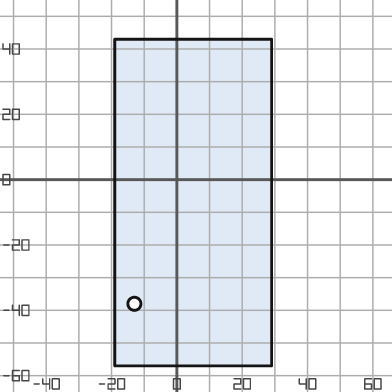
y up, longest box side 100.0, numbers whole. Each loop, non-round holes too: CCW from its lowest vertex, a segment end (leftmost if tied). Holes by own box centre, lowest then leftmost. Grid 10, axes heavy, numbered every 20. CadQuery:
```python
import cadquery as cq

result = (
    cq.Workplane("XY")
    .moveTo(-19.0, -57.0)
    .lineTo(29.0, -57.0)
    .lineTo(29.0, 43.0)
    .lineTo(-19.0, 43.0)
    .close()
    .moveTo(-13.0, -38.0)
    .circle(2.0)
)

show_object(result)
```